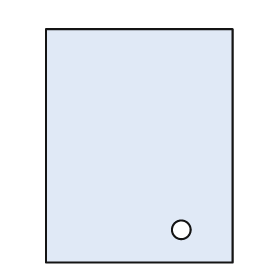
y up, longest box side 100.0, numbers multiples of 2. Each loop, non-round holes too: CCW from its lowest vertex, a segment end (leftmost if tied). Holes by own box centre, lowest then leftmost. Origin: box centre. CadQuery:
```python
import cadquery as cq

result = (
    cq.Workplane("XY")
    .moveTo(-40.0, -50.0)
    .lineTo(40.0, -50.0)
    .lineTo(40.0, 50.0)
    .lineTo(-40.0, 50.0)
    .close()
    .moveTo(18.0, -36.0)
    .circle(4.0)
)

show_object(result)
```